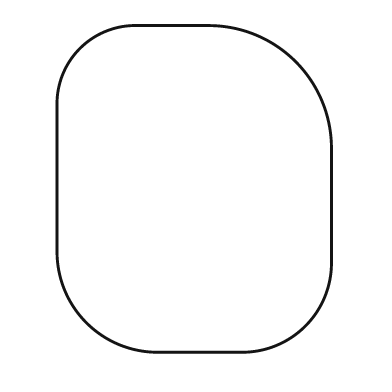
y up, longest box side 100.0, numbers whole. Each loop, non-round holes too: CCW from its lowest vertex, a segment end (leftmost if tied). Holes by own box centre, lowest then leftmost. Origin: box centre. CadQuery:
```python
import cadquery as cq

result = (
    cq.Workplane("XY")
    .moveTo(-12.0, -50.0)
    .lineTo(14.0, -50.0)
    .threePointArc((34.0, -42.0), (42.0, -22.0))
    .lineTo(42.0, 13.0)
    .threePointArc((31.0, 39.0), (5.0, 50.0))
    .lineTo(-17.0, 50.0)
    .threePointArc((-35.0, 43.0), (-42.0, 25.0))
    .lineTo(-42.0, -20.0)
    .threePointArc((-33.0, -41.0), (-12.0, -50.0))
    .close()
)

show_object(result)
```